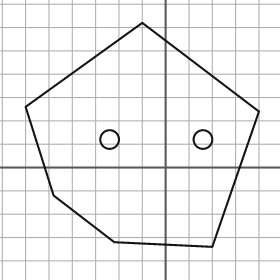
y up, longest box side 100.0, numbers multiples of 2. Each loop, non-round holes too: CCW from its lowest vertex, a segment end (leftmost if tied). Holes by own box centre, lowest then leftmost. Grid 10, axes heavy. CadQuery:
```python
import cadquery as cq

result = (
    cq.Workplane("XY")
    .moveTo(20.0, -34.0)
    .lineTo(40.0, 24.0)
    .lineTo(-10.0, 62.0)
    .lineTo(-60.0, 26.0)
    .lineTo(-48.0, -12.0)
    .lineTo(-22.0, -32.0)
    .close()
    .moveTo(-24.0, 12.0)
    .circle(4.0)
    .moveTo(16.0, 12.0)
    .circle(4.0)
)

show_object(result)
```